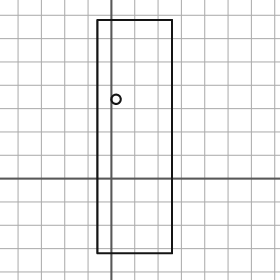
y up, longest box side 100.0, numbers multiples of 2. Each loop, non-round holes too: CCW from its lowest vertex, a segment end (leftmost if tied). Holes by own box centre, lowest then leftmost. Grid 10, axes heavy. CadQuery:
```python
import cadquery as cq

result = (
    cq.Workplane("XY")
    .moveTo(-6.0, -32.0)
    .lineTo(26.0, -32.0)
    .lineTo(26.0, 68.0)
    .lineTo(-6.0, 68.0)
    .close()
    .moveTo(2.0, 34.0)
    .circle(2.0)
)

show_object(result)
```